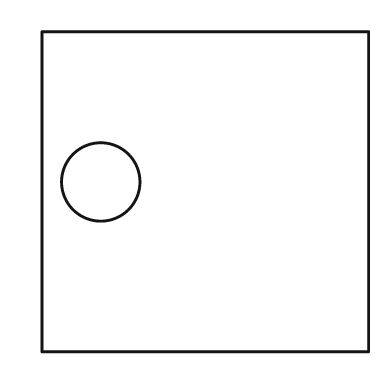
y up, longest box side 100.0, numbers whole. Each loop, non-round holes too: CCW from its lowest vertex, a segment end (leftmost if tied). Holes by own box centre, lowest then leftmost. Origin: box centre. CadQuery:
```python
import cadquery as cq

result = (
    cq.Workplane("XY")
    .moveTo(-50.0, -49.0)
    .lineTo(50.0, -49.0)
    .lineTo(50.0, 49.0)
    .lineTo(-50.0, 49.0)
    .close()
    .moveTo(-32.0, 3.0)
    .circle(12.0)
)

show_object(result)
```